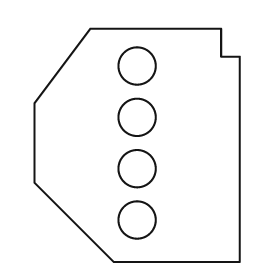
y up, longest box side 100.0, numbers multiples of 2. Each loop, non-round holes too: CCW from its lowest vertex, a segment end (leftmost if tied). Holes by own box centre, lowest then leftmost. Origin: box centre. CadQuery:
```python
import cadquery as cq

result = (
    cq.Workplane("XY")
    .moveTo(-10.0, -50.0)
    .lineTo(44.0, -50.0)
    .lineTo(44.0, 38.0)
    .lineTo(36.0, 38.0)
    .lineTo(36.0, 50.0)
    .lineTo(-20.0, 50.0)
    .lineTo(-44.0, 18.0)
    .lineTo(-44.0, -16.0)
    .close()
    .moveTo(0.0, -32.0)
    .circle(8.0)
    .moveTo(0.0, -10.0)
    .circle(8.0)
    .moveTo(0.0, 12.0)
    .circle(8.0)
    .moveTo(0.0, 34.0)
    .circle(8.0)
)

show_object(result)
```